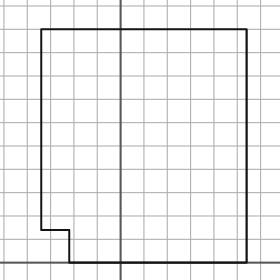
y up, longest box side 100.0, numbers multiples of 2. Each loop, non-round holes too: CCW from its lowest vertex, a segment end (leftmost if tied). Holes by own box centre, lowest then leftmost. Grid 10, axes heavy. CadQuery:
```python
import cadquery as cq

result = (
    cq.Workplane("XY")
    .moveTo(-22.0, 0.0)
    .lineTo(54.0, 0.0)
    .lineTo(54.0, 100.0)
    .lineTo(-34.0, 100.0)
    .lineTo(-34.0, 14.0)
    .lineTo(-22.0, 14.0)
    .close()
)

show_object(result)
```